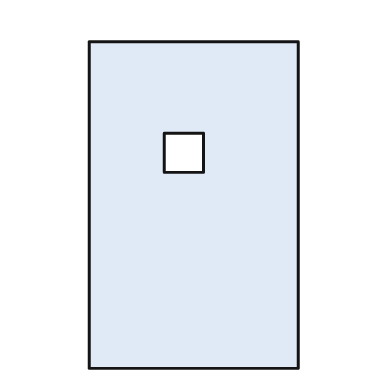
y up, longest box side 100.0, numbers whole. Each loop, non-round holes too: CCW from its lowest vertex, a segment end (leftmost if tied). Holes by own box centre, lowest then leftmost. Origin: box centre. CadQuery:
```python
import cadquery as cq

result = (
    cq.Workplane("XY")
    .moveTo(-32.0, -50.0)
    .lineTo(32.0, -50.0)
    .lineTo(32.0, 50.0)
    .lineTo(-32.0, 50.0)
    .close()
    .moveTo(-9.0, 10.0)
    .lineTo(3.0, 10.0)
    .lineTo(3.0, 22.0)
    .lineTo(-9.0, 22.0)
    .close()
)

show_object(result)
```